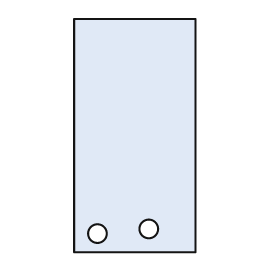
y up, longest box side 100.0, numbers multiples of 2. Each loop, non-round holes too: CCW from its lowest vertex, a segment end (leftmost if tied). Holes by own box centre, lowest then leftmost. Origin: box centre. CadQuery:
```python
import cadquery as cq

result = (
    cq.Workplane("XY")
    .moveTo(-26.0, -50.0)
    .lineTo(26.0, -50.0)
    .lineTo(26.0, 50.0)
    .lineTo(-26.0, 50.0)
    .close()
    .moveTo(-16.0, -42.0)
    .circle(4.0)
    .moveTo(6.0, -40.0)
    .circle(4.0)
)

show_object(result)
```